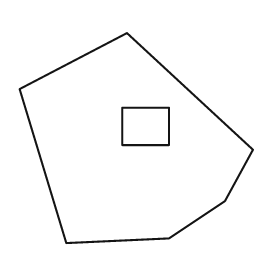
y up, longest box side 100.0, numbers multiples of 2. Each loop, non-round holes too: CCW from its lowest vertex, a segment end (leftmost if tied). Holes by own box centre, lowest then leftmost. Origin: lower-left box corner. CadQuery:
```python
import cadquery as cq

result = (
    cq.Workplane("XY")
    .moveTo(20.0, 0.0)
    .lineTo(64.0, 2.0)
    .lineTo(88.0, 18.0)
    .lineTo(100.0, 40.0)
    .lineTo(46.0, 90.0)
    .lineTo(0.0, 66.0)
    .close()
    .moveTo(44.0, 42.0)
    .lineTo(64.0, 42.0)
    .lineTo(64.0, 58.0)
    .lineTo(44.0, 58.0)
    .close()
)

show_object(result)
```